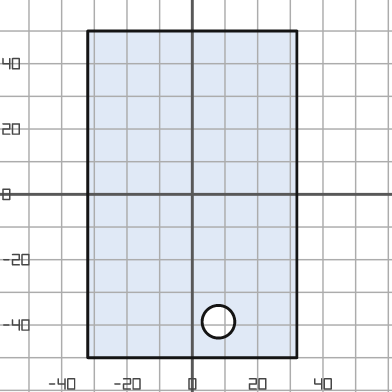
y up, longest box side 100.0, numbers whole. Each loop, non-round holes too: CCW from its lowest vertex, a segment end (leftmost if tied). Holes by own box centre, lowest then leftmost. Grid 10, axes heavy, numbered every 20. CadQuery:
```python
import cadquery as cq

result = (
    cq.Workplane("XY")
    .moveTo(-32.0, -50.0)
    .lineTo(32.0, -50.0)
    .lineTo(32.0, 50.0)
    .lineTo(-32.0, 50.0)
    .close()
    .moveTo(8.0, -39.0)
    .circle(5.0)
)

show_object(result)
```